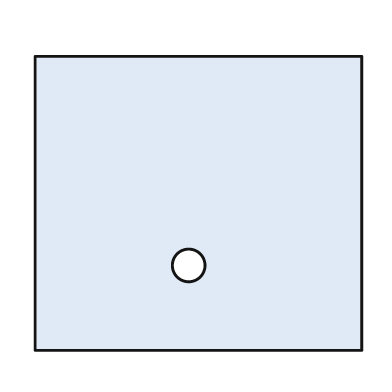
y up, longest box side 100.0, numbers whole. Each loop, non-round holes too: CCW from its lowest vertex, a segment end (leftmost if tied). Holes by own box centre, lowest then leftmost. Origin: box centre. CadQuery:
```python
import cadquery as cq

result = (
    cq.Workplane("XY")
    .moveTo(-50.0, -45.0)
    .lineTo(50.0, -45.0)
    .lineTo(50.0, 45.0)
    .lineTo(-50.0, 45.0)
    .close()
    .moveTo(-3.0, -19.0)
    .circle(5.0)
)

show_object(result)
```